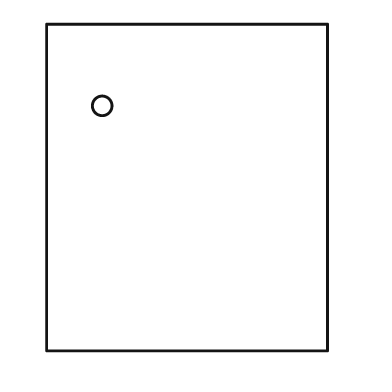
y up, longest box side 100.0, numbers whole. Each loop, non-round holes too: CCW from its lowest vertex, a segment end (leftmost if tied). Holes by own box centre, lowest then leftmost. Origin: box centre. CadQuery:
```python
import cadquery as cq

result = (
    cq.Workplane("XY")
    .moveTo(-43.0, -50.0)
    .lineTo(43.0, -50.0)
    .lineTo(43.0, 50.0)
    .lineTo(-43.0, 50.0)
    .close()
    .moveTo(-26.0, 25.0)
    .circle(3.0)
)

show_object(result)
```